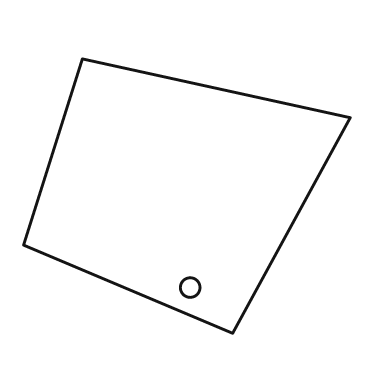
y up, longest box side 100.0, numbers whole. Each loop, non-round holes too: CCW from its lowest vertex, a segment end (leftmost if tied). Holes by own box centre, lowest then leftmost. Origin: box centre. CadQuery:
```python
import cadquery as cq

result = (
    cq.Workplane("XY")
    .moveTo(14.0, -42.0)
    .lineTo(50.0, 24.0)
    .lineTo(-32.0, 42.0)
    .lineTo(-50.0, -15.0)
    .close()
    .moveTo(1.0, -28.0)
    .circle(3.0)
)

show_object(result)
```